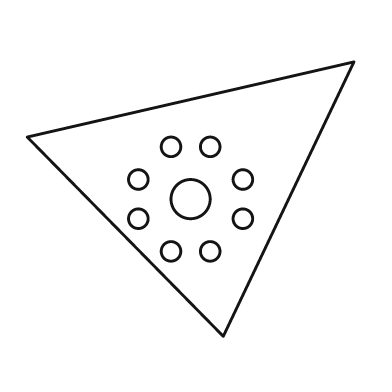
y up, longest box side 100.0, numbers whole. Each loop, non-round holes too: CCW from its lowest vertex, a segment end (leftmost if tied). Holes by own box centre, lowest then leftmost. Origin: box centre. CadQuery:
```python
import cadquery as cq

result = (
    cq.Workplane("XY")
    .moveTo(10.0, -42.0)
    .lineTo(50.0, 42.0)
    .lineTo(-50.0, 19.0)
    .close()
    .moveTo(-6.0, -16.0)
    .circle(3.0)
    .moveTo(6.0, -16.0)
    .circle(3.0)
    .moveTo(-16.0, -6.0)
    .circle(3.0)
    .moveTo(16.0, -6.0)
    .circle(3.0)
    .moveTo(0.0, 0.0)
    .circle(6.0)
    .moveTo(-16.0, 6.0)
    .circle(3.0)
    .moveTo(16.0, 6.0)
    .circle(3.0)
    .moveTo(-6.0, 16.0)
    .circle(3.0)
    .moveTo(6.0, 16.0)
    .circle(3.0)
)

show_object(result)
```